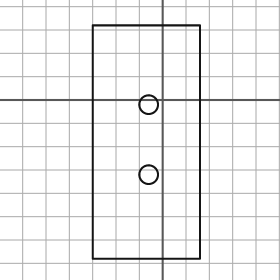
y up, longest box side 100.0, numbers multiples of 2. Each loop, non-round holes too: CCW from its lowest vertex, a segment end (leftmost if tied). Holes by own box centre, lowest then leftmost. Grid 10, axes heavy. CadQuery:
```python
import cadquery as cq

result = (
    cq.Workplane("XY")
    .moveTo(-30.0, -68.0)
    .lineTo(16.0, -68.0)
    .lineTo(16.0, 32.0)
    .lineTo(-30.0, 32.0)
    .close()
    .moveTo(-6.0, -32.0)
    .circle(4.0)
    .moveTo(-6.0, -2.0)
    .circle(4.0)
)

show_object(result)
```